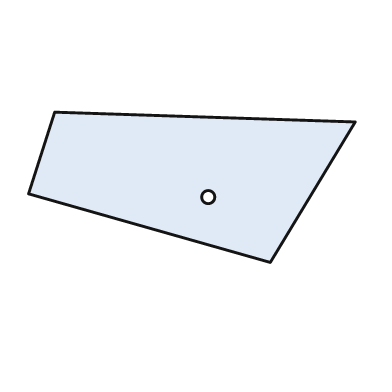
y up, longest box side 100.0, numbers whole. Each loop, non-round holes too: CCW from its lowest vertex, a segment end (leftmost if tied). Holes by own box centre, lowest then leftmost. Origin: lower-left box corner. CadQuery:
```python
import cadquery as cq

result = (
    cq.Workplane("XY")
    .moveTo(74.0, 0.0)
    .lineTo(100.0, 43.0)
    .lineTo(8.0, 46.0)
    .lineTo(0.0, 21.0)
    .close()
    .moveTo(55.0, 20.0)
    .circle(2.0)
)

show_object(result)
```